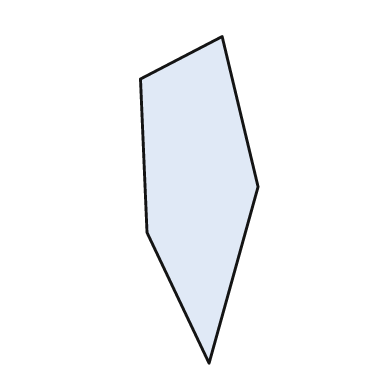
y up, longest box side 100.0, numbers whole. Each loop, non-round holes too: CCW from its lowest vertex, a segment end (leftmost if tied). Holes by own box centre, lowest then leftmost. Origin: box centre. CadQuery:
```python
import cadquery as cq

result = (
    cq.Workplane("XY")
    .moveTo(3.0, -50.0)
    .lineTo(18.0, 4.0)
    .lineTo(7.0, 50.0)
    .lineTo(-18.0, 37.0)
    .lineTo(-16.0, -10.0)
    .close()
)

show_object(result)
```